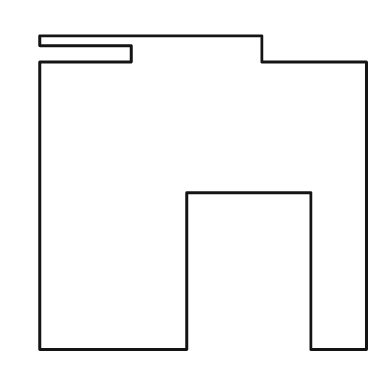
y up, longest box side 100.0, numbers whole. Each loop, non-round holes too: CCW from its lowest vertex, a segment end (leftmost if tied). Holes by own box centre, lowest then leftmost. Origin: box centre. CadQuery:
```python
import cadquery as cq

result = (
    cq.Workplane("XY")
    .moveTo(-50.0, -48.0)
    .lineTo(-5.0, -48.0)
    .lineTo(-5.0, 0.0)
    .lineTo(33.0, 0.0)
    .lineTo(33.0, -48.0)
    .lineTo(50.0, -48.0)
    .lineTo(50.0, 40.0)
    .lineTo(18.0, 40.0)
    .lineTo(18.0, 48.0)
    .lineTo(-50.0, 48.0)
    .lineTo(-50.0, 45.0)
    .lineTo(-22.0, 45.0)
    .lineTo(-22.0, 40.0)
    .lineTo(-50.0, 40.0)
    .close()
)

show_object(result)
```